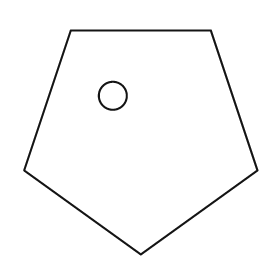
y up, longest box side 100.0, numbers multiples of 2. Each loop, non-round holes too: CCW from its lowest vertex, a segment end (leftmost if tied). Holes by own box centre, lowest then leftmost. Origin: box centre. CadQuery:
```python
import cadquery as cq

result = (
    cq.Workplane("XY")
    .moveTo(0.0, -48.0)
    .lineTo(50.0, -12.0)
    .lineTo(30.0, 48.0)
    .lineTo(-30.0, 48.0)
    .lineTo(-50.0, -12.0)
    .close()
    .moveTo(-12.0, 20.0)
    .circle(6.0)
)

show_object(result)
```